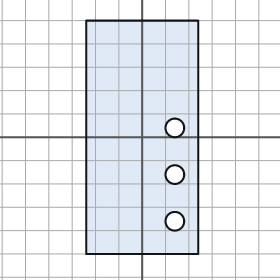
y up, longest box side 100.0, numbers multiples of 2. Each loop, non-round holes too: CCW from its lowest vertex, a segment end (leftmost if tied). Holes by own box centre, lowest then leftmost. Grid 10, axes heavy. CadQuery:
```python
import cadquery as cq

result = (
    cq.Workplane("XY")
    .moveTo(-24.0, -50.0)
    .lineTo(24.0, -50.0)
    .lineTo(24.0, 50.0)
    .lineTo(-24.0, 50.0)
    .close()
    .moveTo(14.0, -36.0)
    .circle(4.0)
    .moveTo(14.0, -16.0)
    .circle(4.0)
    .moveTo(14.0, 4.0)
    .circle(4.0)
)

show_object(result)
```